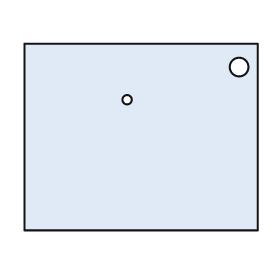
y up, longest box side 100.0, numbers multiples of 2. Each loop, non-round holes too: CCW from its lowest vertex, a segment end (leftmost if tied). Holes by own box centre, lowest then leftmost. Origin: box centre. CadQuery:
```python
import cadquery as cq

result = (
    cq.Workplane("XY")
    .moveTo(-50.0, -40.0)
    .lineTo(50.0, -40.0)
    .lineTo(50.0, 40.0)
    .lineTo(-50.0, 40.0)
    .close()
    .moveTo(-6.0, 16.0)
    .circle(2.0)
    .moveTo(42.0, 30.0)
    .circle(4.0)
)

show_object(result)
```